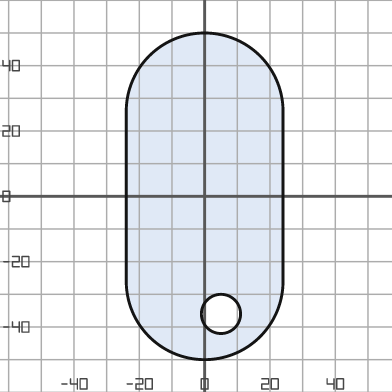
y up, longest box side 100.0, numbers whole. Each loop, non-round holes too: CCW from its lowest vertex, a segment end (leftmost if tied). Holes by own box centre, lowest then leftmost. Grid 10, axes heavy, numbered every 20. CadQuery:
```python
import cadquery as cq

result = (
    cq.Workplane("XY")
    .moveTo(-24.0, -26.0)
    .threePointArc((0.0, -50.0), (24.0, -26.0))
    .lineTo(24.0, 26.0)
    .threePointArc((0.0, 50.0), (-24.0, 26.0))
    .close()
    .moveTo(5.0, -36.0)
    .circle(6.0)
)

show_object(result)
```